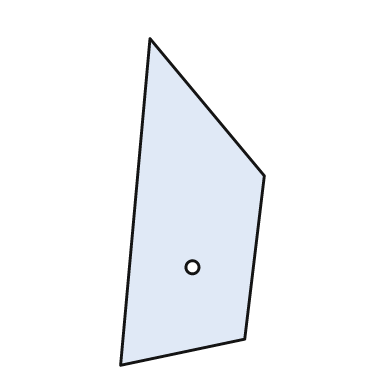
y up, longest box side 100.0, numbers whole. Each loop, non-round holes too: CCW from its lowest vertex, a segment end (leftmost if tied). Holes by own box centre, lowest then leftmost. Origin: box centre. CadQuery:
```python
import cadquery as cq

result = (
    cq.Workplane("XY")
    .moveTo(-22.0, -50.0)
    .lineTo(16.0, -42.0)
    .lineTo(22.0, 8.0)
    .lineTo(-13.0, 50.0)
    .close()
    .moveTo(0.0, -20.0)
    .circle(2.0)
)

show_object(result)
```